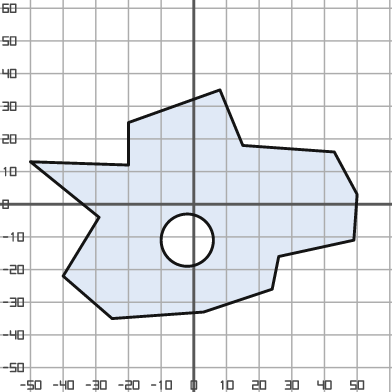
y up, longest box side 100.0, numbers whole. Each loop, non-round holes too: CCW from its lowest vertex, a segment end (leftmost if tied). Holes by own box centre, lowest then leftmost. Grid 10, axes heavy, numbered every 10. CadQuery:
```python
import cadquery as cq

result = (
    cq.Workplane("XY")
    .moveTo(-25.0, -35.0)
    .lineTo(3.0, -33.0)
    .lineTo(24.0, -26.0)
    .lineTo(26.0, -16.0)
    .lineTo(49.0, -11.0)
    .lineTo(50.0, 3.0)
    .lineTo(43.0, 16.0)
    .lineTo(15.0, 18.0)
    .lineTo(8.0, 35.0)
    .lineTo(-20.0, 25.0)
    .lineTo(-20.0, 12.0)
    .lineTo(-50.0, 13.0)
    .lineTo(-29.0, -4.0)
    .lineTo(-40.0, -22.0)
    .close()
    .moveTo(-2.0, -11.0)
    .circle(8.0)
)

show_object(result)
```